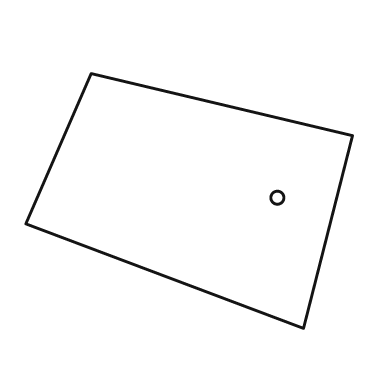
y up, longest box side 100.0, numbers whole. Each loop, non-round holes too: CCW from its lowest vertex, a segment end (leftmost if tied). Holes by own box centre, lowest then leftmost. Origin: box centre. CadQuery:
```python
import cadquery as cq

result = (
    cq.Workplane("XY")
    .moveTo(35.0, -39.0)
    .lineTo(50.0, 20.0)
    .lineTo(-30.0, 39.0)
    .lineTo(-50.0, -7.0)
    .close()
    .moveTo(27.0, 1.0)
    .circle(2.0)
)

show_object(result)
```